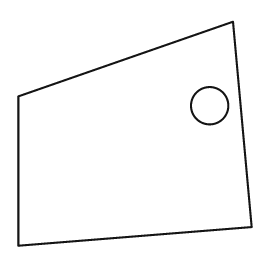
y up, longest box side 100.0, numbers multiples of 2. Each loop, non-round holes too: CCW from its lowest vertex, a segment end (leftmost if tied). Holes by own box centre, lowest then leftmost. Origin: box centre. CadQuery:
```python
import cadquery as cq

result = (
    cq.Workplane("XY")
    .moveTo(-50.0, -48.0)
    .lineTo(50.0, -40.0)
    .lineTo(42.0, 48.0)
    .lineTo(-50.0, 16.0)
    .close()
    .moveTo(32.0, 12.0)
    .circle(8.0)
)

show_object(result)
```